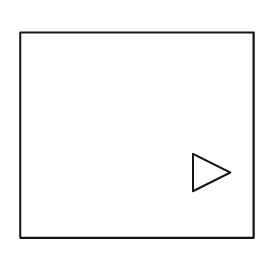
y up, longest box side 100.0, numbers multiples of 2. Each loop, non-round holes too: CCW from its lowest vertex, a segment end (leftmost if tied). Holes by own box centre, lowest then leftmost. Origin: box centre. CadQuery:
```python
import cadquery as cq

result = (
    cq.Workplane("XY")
    .moveTo(-50.0, -44.0)
    .lineTo(50.0, -44.0)
    .lineTo(50.0, 44.0)
    .lineTo(-50.0, 44.0)
    .close()
    .moveTo(24.0, -24.0)
    .lineTo(40.0, -16.0)
    .lineTo(24.0, -8.0)
    .close()
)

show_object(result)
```